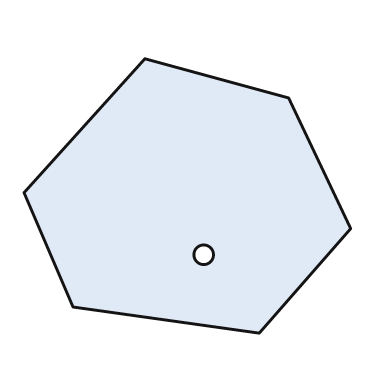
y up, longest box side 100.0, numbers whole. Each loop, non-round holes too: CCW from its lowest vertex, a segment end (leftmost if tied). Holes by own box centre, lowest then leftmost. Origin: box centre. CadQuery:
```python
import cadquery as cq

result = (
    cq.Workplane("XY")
    .moveTo(22.0, -42.0)
    .lineTo(50.0, -10.0)
    .lineTo(31.0, 30.0)
    .lineTo(-13.0, 42.0)
    .lineTo(-50.0, 1.0)
    .lineTo(-35.0, -34.0)
    .close()
    .moveTo(5.0, -18.0)
    .circle(3.0)
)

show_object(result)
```